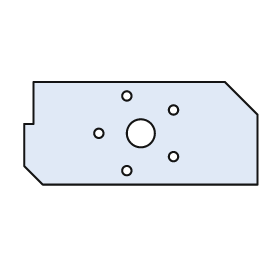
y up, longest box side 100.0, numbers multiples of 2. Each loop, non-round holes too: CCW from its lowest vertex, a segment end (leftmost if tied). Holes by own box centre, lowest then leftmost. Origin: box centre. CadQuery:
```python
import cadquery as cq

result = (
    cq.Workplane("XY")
    .moveTo(-42.0, -22.0)
    .lineTo(50.0, -22.0)
    .lineTo(50.0, 8.0)
    .lineTo(36.0, 22.0)
    .lineTo(-46.0, 22.0)
    .lineTo(-46.0, 4.0)
    .lineTo(-50.0, 4.0)
    .lineTo(-50.0, -14.0)
    .close()
    .moveTo(-6.0, -16.0)
    .circle(2.0)
    .moveTo(14.0, -10.0)
    .circle(2.0)
    .moveTo(-18.0, 0.0)
    .circle(2.0)
    .moveTo(0.0, 0.0)
    .circle(6.0)
    .moveTo(14.0, 10.0)
    .circle(2.0)
    .moveTo(-6.0, 16.0)
    .circle(2.0)
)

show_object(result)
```